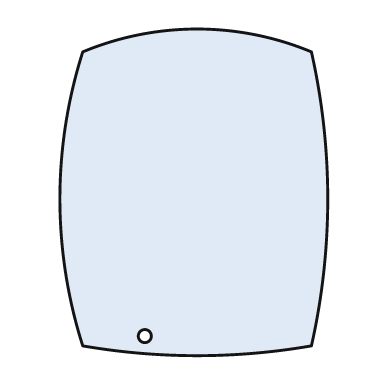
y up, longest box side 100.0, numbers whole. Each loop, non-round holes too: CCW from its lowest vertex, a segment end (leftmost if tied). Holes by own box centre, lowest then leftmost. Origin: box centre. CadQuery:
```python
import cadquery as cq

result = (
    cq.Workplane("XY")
    .moveTo(-34.0, -47.0)
    .threePointArc((1.0, -50.0), (36.0, -47.0))
    .threePointArc((41.0, -2.0), (36.0, 43.0))
    .threePointArc((1.0, 50.0), (-34.0, 43.0))
    .threePointArc((-41.0, -2.0), (-34.0, -47.0))
    .close()
    .moveTo(-15.0, -44.0)
    .circle(2.0)
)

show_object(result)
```